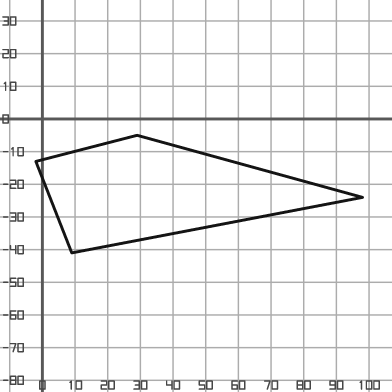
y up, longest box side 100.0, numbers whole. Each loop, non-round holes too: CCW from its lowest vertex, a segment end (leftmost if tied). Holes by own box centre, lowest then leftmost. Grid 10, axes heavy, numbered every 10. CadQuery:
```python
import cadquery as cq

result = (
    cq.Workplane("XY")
    .moveTo(9.0, -41.0)
    .lineTo(98.0, -24.0)
    .lineTo(29.0, -5.0)
    .lineTo(-2.0, -13.0)
    .close()
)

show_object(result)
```